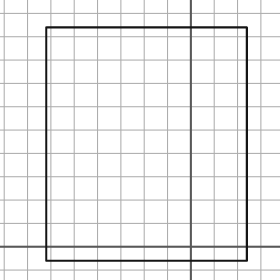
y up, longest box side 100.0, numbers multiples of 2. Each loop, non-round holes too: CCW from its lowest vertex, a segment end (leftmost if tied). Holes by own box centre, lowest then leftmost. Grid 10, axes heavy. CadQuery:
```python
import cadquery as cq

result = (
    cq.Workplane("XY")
    .moveTo(-62.0, -6.0)
    .lineTo(24.0, -6.0)
    .lineTo(24.0, 94.0)
    .lineTo(-62.0, 94.0)
    .close()
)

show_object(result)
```